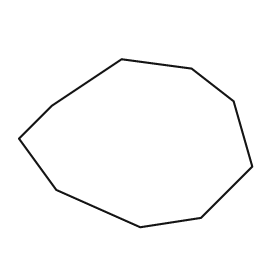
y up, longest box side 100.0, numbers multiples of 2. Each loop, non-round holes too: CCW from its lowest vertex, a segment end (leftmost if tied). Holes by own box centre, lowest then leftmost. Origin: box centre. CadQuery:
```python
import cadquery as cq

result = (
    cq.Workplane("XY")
    .moveTo(2.0, -36.0)
    .lineTo(28.0, -32.0)
    .lineTo(50.0, -10.0)
    .lineTo(42.0, 18.0)
    .lineTo(24.0, 32.0)
    .lineTo(-6.0, 36.0)
    .lineTo(-36.0, 16.0)
    .lineTo(-50.0, 2.0)
    .lineTo(-34.0, -20.0)
    .close()
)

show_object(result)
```